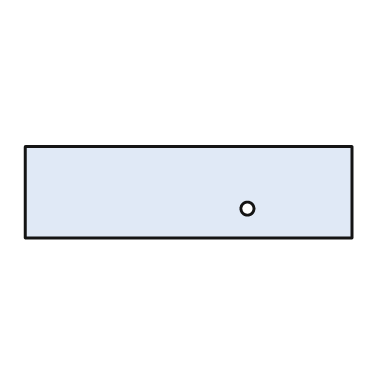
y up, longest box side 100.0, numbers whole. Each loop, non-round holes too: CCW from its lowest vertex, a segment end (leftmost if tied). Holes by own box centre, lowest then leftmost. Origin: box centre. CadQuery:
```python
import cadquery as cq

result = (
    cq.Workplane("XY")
    .moveTo(-50.0, -14.0)
    .lineTo(50.0, -14.0)
    .lineTo(50.0, 14.0)
    .lineTo(-50.0, 14.0)
    .close()
    .moveTo(18.0, -5.0)
    .circle(2.0)
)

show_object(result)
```